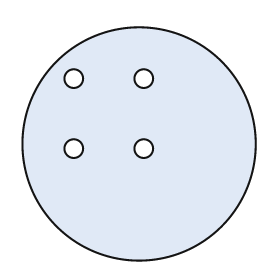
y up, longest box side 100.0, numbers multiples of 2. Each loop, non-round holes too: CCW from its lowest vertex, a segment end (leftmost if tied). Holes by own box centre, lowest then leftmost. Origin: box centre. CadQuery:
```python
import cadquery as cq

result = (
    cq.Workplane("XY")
    .moveTo(0.0, 0.0)
    .circle(50.0)
    .moveTo(-28.0, -2.0)
    .circle(4.0)
    .moveTo(2.0, -2.0)
    .circle(4.0)
    .moveTo(-28.0, 28.0)
    .circle(4.0)
    .moveTo(2.0, 28.0)
    .circle(4.0)
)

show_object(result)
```